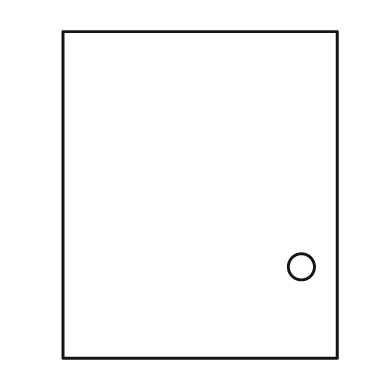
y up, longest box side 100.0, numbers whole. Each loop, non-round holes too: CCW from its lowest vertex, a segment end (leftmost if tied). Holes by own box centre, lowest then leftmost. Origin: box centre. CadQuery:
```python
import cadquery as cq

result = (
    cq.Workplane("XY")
    .moveTo(-42.0, -50.0)
    .lineTo(42.0, -50.0)
    .lineTo(42.0, 50.0)
    .lineTo(-42.0, 50.0)
    .close()
    .moveTo(31.0, -22.0)
    .circle(4.0)
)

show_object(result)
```